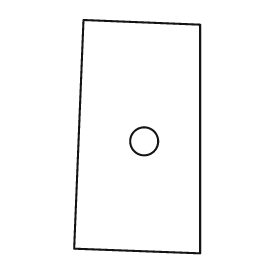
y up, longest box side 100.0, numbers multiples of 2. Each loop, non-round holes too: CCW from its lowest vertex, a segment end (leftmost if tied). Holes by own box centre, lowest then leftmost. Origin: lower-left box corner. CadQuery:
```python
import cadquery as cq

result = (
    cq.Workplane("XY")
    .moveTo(54.0, 0.0)
    .lineTo(54.0, 98.0)
    .lineTo(4.0, 100.0)
    .lineTo(0.0, 2.0)
    .close()
    .moveTo(30.0, 48.0)
    .circle(6.0)
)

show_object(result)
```